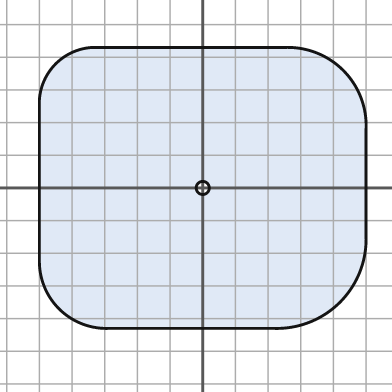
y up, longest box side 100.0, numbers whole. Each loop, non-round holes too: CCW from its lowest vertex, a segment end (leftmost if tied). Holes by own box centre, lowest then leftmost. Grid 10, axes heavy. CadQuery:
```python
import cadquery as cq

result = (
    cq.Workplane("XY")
    .moveTo(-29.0, -43.0)
    .lineTo(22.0, -43.0)
    .threePointArc((42.0, -35.0), (50.0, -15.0))
    .lineTo(50.0, 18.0)
    .threePointArc((43.0, 36.0), (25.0, 43.0))
    .lineTo(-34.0, 43.0)
    .threePointArc((-45.0, 38.0), (-50.0, 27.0))
    .lineTo(-50.0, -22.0)
    .threePointArc((-44.0, -37.0), (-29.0, -43.0))
    .close()
    .moveTo(0.0, 0.0)
    .circle(2.0)
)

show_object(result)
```